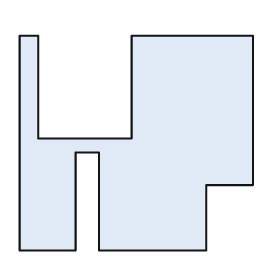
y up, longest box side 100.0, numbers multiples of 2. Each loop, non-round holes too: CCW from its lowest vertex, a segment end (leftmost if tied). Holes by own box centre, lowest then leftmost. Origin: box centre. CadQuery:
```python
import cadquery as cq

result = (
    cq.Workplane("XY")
    .moveTo(-50.0, -46.0)
    .lineTo(-26.0, -46.0)
    .lineTo(-26.0, -4.0)
    .lineTo(-16.0, -4.0)
    .lineTo(-16.0, -46.0)
    .lineTo(30.0, -46.0)
    .lineTo(30.0, -18.0)
    .lineTo(50.0, -18.0)
    .lineTo(50.0, 46.0)
    .lineTo(-2.0, 46.0)
    .lineTo(-2.0, 2.0)
    .lineTo(-42.0, 2.0)
    .lineTo(-42.0, 46.0)
    .lineTo(-50.0, 46.0)
    .close()
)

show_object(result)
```